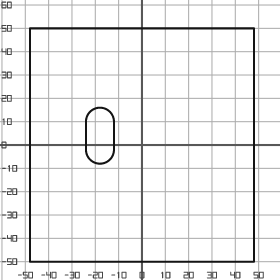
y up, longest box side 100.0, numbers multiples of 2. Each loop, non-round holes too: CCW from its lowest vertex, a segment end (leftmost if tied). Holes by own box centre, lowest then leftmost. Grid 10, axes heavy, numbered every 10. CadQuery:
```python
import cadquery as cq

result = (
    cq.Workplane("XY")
    .moveTo(-48.0, -50.0)
    .lineTo(48.0, -50.0)
    .lineTo(48.0, 50.0)
    .lineTo(-48.0, 50.0)
    .close()
    .moveTo(-24.0, -2.0)
    .threePointArc((-18.0, -8.0), (-12.0, -2.0))
    .lineTo(-12.0, 10.0)
    .threePointArc((-18.0, 16.0), (-24.0, 10.0))
    .close()
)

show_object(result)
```